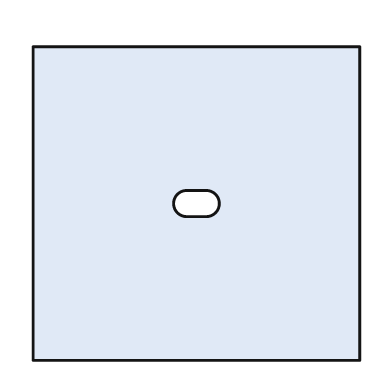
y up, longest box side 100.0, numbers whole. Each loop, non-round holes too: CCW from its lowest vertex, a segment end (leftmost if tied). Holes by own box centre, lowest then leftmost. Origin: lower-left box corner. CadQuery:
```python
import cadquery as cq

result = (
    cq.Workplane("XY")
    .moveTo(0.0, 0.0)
    .lineTo(100.0, 0.0)
    .lineTo(100.0, 96.0)
    .lineTo(0.0, 96.0)
    .close()
    .moveTo(47.0, 44.0)
    .lineTo(53.0, 44.0)
    .threePointArc((57.0, 48.0), (53.0, 52.0))
    .lineTo(47.0, 52.0)
    .threePointArc((43.0, 48.0), (47.0, 44.0))
    .close()
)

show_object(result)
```